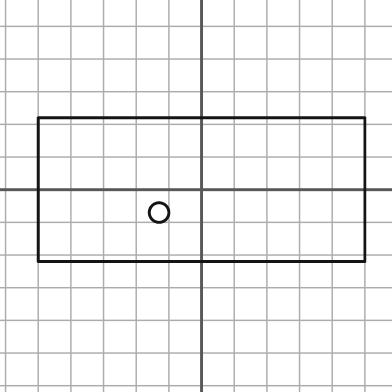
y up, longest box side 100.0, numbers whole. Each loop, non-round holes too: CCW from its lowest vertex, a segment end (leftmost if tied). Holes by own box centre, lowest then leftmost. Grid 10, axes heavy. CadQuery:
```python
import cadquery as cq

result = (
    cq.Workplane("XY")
    .moveTo(-50.0, -22.0)
    .lineTo(50.0, -22.0)
    .lineTo(50.0, 22.0)
    .lineTo(-50.0, 22.0)
    .close()
    .moveTo(-13.0, -7.0)
    .circle(3.0)
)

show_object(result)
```